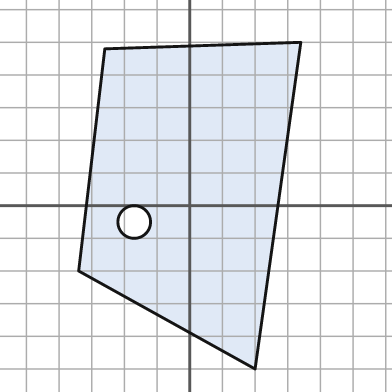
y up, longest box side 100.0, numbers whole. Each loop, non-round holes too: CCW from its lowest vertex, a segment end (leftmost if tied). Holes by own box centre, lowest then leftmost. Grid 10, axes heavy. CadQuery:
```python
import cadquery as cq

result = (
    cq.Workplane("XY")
    .moveTo(20.0, -50.0)
    .lineTo(34.0, 50.0)
    .lineTo(-26.0, 48.0)
    .lineTo(-34.0, -20.0)
    .close()
    .moveTo(-17.0, -5.0)
    .circle(5.0)
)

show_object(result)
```